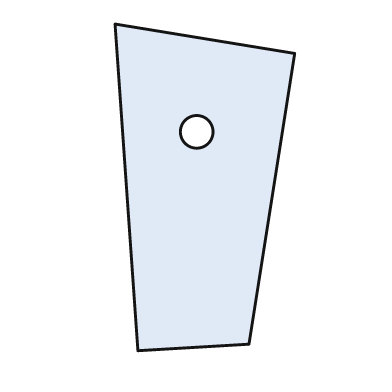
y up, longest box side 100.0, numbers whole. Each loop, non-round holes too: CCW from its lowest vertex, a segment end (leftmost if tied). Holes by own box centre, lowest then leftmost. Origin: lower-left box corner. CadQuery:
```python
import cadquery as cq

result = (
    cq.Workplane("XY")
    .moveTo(7.0, 0.0)
    .lineTo(41.0, 2.0)
    .lineTo(55.0, 91.0)
    .lineTo(0.0, 100.0)
    .close()
    .moveTo(25.0, 67.0)
    .circle(5.0)
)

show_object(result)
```